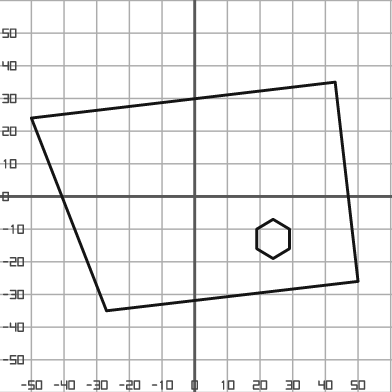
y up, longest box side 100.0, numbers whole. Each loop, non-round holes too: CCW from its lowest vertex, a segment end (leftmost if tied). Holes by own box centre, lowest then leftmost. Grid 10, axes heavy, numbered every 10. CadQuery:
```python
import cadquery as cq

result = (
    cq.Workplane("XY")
    .moveTo(-27.0, -35.0)
    .lineTo(50.0, -26.0)
    .lineTo(43.0, 35.0)
    .lineTo(-50.0, 24.0)
    .close()
    .moveTo(24.0, -19.0)
    .lineTo(29.0, -16.0)
    .lineTo(29.0, -10.0)
    .lineTo(24.0, -7.0)
    .lineTo(19.0, -10.0)
    .lineTo(19.0, -16.0)
    .close()
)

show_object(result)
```